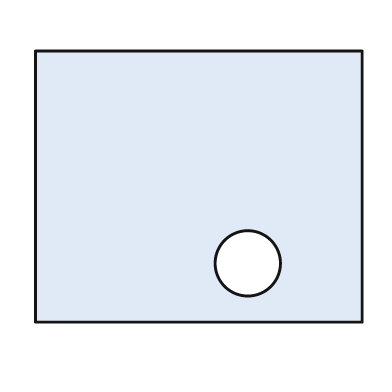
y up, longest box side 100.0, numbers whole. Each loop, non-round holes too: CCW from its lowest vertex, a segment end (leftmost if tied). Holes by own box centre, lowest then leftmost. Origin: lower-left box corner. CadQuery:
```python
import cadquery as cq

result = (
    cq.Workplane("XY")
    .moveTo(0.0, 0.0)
    .lineTo(100.0, 0.0)
    .lineTo(100.0, 83.0)
    .lineTo(0.0, 83.0)
    .close()
    .moveTo(65.0, 18.0)
    .circle(10.0)
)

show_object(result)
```